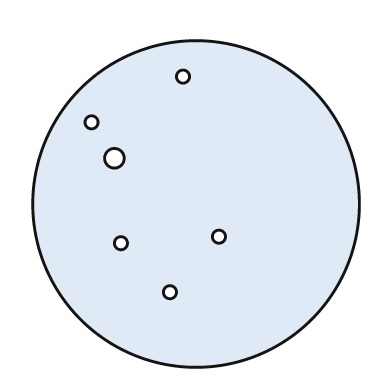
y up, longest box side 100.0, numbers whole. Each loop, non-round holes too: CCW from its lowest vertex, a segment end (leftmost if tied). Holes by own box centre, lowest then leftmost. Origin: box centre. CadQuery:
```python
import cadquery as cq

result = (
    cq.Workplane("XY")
    .moveTo(0.0, 0.0)
    .circle(50.0)
    .moveTo(-8.0, -27.0)
    .circle(2.0)
    .moveTo(-23.0, -12.0)
    .circle(2.0)
    .moveTo(7.0, -10.0)
    .circle(2.0)
    .moveTo(-25.0, 14.0)
    .circle(3.0)
    .moveTo(-32.0, 25.0)
    .circle(2.0)
    .moveTo(-4.0, 39.0)
    .circle(2.0)
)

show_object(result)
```